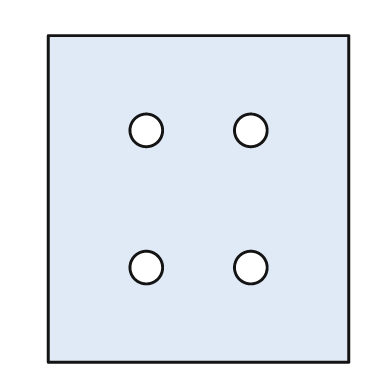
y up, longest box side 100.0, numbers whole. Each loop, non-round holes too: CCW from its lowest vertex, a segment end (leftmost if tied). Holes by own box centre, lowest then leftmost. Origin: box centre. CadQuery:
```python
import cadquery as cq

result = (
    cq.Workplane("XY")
    .moveTo(-46.0, -50.0)
    .lineTo(46.0, -50.0)
    .lineTo(46.0, 50.0)
    .lineTo(-46.0, 50.0)
    .close()
    .moveTo(-16.0, -21.0)
    .circle(5.0)
    .moveTo(16.0, -21.0)
    .circle(5.0)
    .moveTo(-16.0, 21.0)
    .circle(5.0)
    .moveTo(16.0, 21.0)
    .circle(5.0)
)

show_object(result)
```